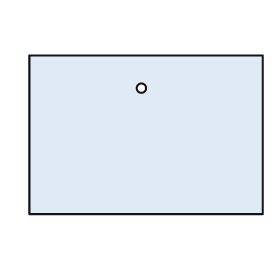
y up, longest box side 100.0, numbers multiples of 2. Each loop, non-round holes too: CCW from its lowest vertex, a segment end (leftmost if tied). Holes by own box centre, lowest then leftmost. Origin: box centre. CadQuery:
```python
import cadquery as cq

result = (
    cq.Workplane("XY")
    .moveTo(-50.0, -34.0)
    .lineTo(50.0, -34.0)
    .lineTo(50.0, 34.0)
    .lineTo(-50.0, 34.0)
    .close()
    .moveTo(-2.0, 20.0)
    .circle(2.0)
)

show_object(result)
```